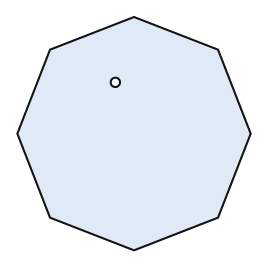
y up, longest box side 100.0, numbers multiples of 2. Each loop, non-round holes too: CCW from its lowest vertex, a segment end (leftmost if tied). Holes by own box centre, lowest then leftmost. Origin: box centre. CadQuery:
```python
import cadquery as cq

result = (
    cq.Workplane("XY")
    .moveTo(0.0, -50.0)
    .lineTo(36.0, -36.0)
    .lineTo(50.0, 0.0)
    .lineTo(36.0, 36.0)
    .lineTo(0.0, 50.0)
    .lineTo(-36.0, 36.0)
    .lineTo(-50.0, 0.0)
    .lineTo(-36.0, -36.0)
    .close()
    .moveTo(-8.0, 22.0)
    .circle(2.0)
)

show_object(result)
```